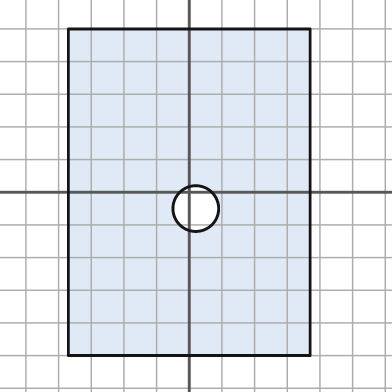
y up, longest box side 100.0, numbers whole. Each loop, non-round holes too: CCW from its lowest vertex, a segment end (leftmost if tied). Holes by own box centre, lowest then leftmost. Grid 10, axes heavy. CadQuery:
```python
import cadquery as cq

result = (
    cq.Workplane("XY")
    .moveTo(-37.0, -50.0)
    .lineTo(37.0, -50.0)
    .lineTo(37.0, 50.0)
    .lineTo(-37.0, 50.0)
    .close()
    .moveTo(2.0, -5.0)
    .circle(7.0)
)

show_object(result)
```